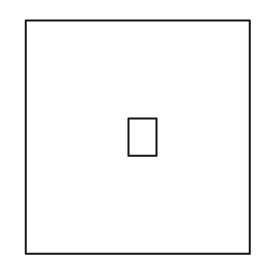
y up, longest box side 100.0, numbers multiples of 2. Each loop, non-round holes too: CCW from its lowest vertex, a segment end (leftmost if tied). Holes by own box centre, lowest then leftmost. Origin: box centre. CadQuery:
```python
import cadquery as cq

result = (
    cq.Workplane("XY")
    .moveTo(-48.0, -50.0)
    .lineTo(48.0, -50.0)
    .lineTo(48.0, 50.0)
    .lineTo(-48.0, 50.0)
    .close()
    .moveTo(-4.0, -8.0)
    .lineTo(8.0, -8.0)
    .lineTo(8.0, 8.0)
    .lineTo(-4.0, 8.0)
    .close()
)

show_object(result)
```